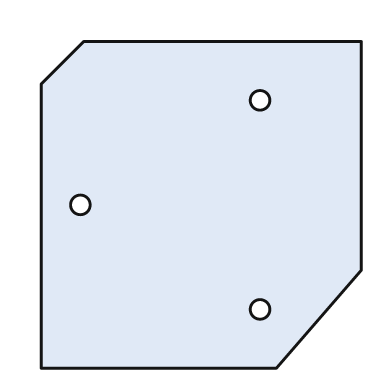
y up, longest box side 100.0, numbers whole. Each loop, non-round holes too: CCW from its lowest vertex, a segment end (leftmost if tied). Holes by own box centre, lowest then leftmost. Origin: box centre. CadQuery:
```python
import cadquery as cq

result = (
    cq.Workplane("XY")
    .moveTo(-49.0, -50.0)
    .lineTo(23.0, -50.0)
    .lineTo(49.0, -20.0)
    .lineTo(49.0, 50.0)
    .lineTo(-36.0, 50.0)
    .lineTo(-49.0, 37.0)
    .close()
    .moveTo(18.0, -32.0)
    .circle(3.0)
    .moveTo(-37.0, 0.0)
    .circle(3.0)
    .moveTo(18.0, 32.0)
    .circle(3.0)
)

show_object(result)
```